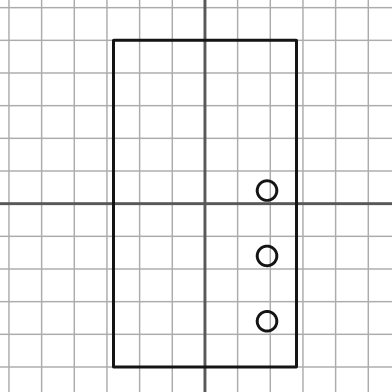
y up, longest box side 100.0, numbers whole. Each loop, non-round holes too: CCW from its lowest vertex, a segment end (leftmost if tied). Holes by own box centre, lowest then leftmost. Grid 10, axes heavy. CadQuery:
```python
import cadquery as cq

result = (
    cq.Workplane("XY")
    .moveTo(-28.0, -50.0)
    .lineTo(28.0, -50.0)
    .lineTo(28.0, 50.0)
    .lineTo(-28.0, 50.0)
    .close()
    .moveTo(19.0, -36.0)
    .circle(3.0)
    .moveTo(19.0, -16.0)
    .circle(3.0)
    .moveTo(19.0, 4.0)
    .circle(3.0)
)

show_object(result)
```